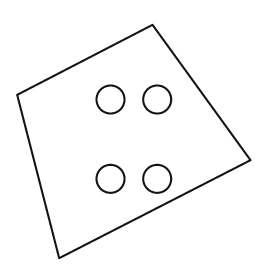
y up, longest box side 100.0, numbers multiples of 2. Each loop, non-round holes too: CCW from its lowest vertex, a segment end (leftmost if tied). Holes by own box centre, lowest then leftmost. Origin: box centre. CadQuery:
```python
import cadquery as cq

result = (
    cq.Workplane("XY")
    .moveTo(-32.0, -50.0)
    .lineTo(50.0, -8.0)
    .lineTo(8.0, 50.0)
    .lineTo(-50.0, 20.0)
    .close()
    .moveTo(-10.0, -16.0)
    .circle(6.0)
    .moveTo(10.0, -16.0)
    .circle(6.0)
    .moveTo(-10.0, 18.0)
    .circle(6.0)
    .moveTo(10.0, 18.0)
    .circle(6.0)
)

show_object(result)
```